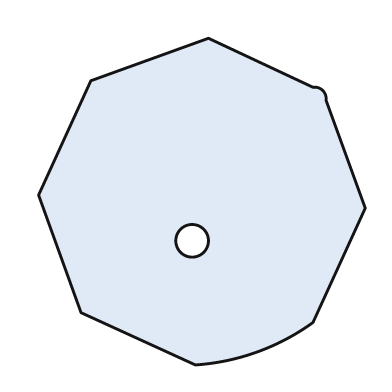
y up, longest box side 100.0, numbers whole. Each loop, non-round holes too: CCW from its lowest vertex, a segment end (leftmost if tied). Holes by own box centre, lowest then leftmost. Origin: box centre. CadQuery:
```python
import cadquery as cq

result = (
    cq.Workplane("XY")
    .moveTo(-2.0, -50.0)
    .threePointArc((17.0, -46.0), (34.0, -37.0))
    .lineTo(50.0, -2.0)
    .lineTo(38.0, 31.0)
    .threePointArc((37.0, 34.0), (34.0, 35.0))
    .lineTo(2.0, 50.0)
    .lineTo(-34.0, 37.0)
    .lineTo(-50.0, 2.0)
    .lineTo(-37.0, -34.0)
    .close()
    .moveTo(-3.0, -12.0)
    .circle(5.0)
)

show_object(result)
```